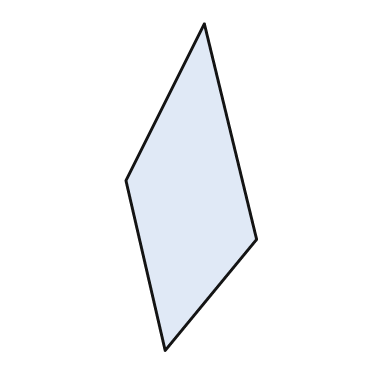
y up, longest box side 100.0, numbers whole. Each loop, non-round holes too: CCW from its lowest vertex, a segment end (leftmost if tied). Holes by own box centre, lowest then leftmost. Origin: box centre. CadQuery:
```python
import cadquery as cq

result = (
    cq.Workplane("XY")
    .moveTo(-8.0, -50.0)
    .lineTo(20.0, -16.0)
    .lineTo(4.0, 50.0)
    .lineTo(-20.0, 2.0)
    .close()
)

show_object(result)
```